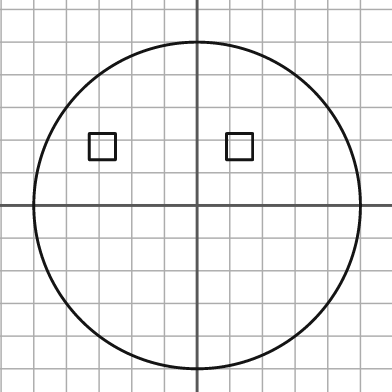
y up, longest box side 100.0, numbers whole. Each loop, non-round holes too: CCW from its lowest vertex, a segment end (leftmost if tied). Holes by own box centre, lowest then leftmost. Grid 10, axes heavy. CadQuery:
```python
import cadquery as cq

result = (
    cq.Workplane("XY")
    .moveTo(0.0, 0.0)
    .circle(50.0)
    .moveTo(-33.0, 14.0)
    .lineTo(-25.0, 14.0)
    .lineTo(-25.0, 22.0)
    .lineTo(-33.0, 22.0)
    .close()
    .moveTo(9.0, 14.0)
    .lineTo(17.0, 14.0)
    .lineTo(17.0, 22.0)
    .lineTo(9.0, 22.0)
    .close()
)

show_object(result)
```